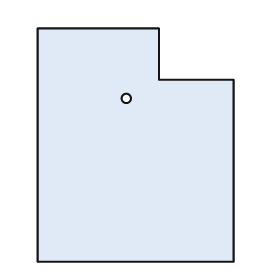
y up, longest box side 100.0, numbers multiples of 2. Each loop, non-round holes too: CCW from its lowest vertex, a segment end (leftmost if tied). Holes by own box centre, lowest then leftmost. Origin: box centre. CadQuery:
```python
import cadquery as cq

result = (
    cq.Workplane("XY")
    .moveTo(-42.0, -50.0)
    .lineTo(42.0, -50.0)
    .lineTo(42.0, 28.0)
    .lineTo(10.0, 28.0)
    .lineTo(10.0, 50.0)
    .lineTo(-42.0, 50.0)
    .close()
    .moveTo(-4.0, 20.0)
    .circle(2.0)
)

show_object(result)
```